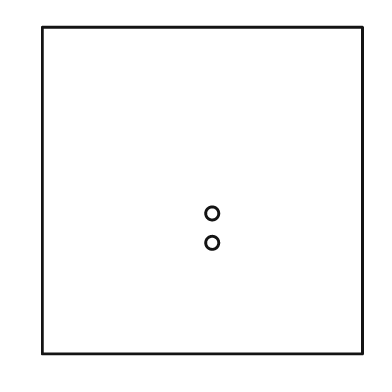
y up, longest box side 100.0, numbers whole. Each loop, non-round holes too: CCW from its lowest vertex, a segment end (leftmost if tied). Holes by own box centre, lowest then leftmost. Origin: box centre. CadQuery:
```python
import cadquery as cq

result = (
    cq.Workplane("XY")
    .moveTo(-49.0, -50.0)
    .lineTo(49.0, -50.0)
    .lineTo(49.0, 50.0)
    .lineTo(-49.0, 50.0)
    .close()
    .moveTo(3.0, -16.0)
    .circle(2.0)
    .moveTo(3.0, -7.0)
    .circle(2.0)
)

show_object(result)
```